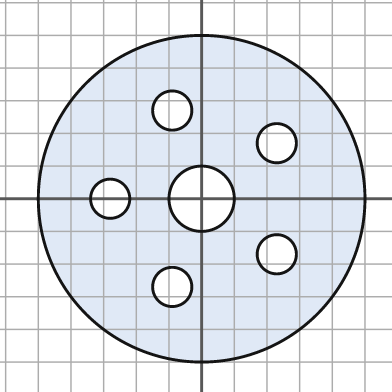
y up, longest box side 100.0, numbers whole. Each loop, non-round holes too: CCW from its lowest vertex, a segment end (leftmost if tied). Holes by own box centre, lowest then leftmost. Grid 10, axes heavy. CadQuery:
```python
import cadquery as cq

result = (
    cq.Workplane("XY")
    .moveTo(0.0, 0.0)
    .circle(50.0)
    .moveTo(-9.0, -27.0)
    .circle(6.0)
    .moveTo(23.0, -17.0)
    .circle(6.0)
    .moveTo(-28.0, 0.0)
    .circle(6.0)
    .moveTo(0.0, 0.0)
    .circle(10.0)
    .moveTo(23.0, 17.0)
    .circle(6.0)
    .moveTo(-9.0, 27.0)
    .circle(6.0)
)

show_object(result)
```